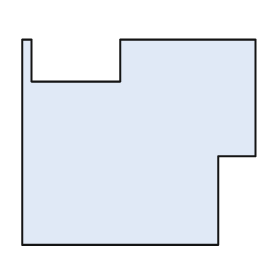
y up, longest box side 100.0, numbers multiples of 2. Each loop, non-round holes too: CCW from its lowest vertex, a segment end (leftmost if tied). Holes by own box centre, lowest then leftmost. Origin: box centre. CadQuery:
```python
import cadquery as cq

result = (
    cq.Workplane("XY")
    .moveTo(-50.0, -44.0)
    .lineTo(34.0, -44.0)
    .lineTo(34.0, -6.0)
    .lineTo(50.0, -6.0)
    .lineTo(50.0, 44.0)
    .lineTo(-8.0, 44.0)
    .lineTo(-8.0, 26.0)
    .lineTo(-46.0, 26.0)
    .lineTo(-46.0, 44.0)
    .lineTo(-50.0, 44.0)
    .close()
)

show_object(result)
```